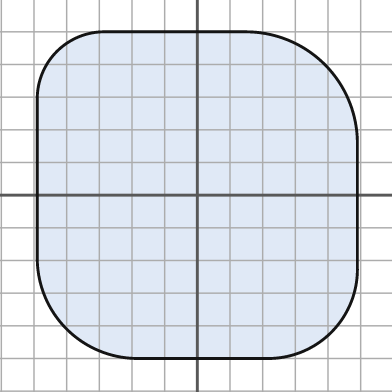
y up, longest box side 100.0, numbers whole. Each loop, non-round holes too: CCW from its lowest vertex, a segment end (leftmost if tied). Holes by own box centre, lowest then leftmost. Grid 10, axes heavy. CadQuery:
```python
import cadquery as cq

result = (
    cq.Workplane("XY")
    .moveTo(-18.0, -50.0)
    .lineTo(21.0, -50.0)
    .threePointArc((41.0, -42.0), (49.0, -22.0))
    .lineTo(49.0, 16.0)
    .threePointArc((39.0, 40.0), (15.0, 50.0))
    .lineTo(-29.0, 50.0)
    .threePointArc((-43.0, 44.0), (-49.0, 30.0))
    .lineTo(-49.0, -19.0)
    .threePointArc((-40.0, -41.0), (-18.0, -50.0))
    .close()
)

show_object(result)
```